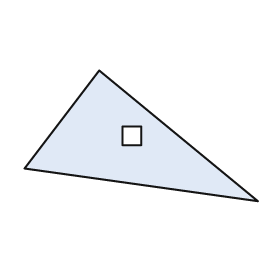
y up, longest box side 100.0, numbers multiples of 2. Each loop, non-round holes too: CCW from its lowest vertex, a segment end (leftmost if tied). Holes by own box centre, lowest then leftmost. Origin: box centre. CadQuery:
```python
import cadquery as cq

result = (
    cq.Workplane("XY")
    .moveTo(50.0, -28.0)
    .lineTo(-18.0, 28.0)
    .lineTo(-50.0, -14.0)
    .close()
    .moveTo(-8.0, -4.0)
    .lineTo(0.0, -4.0)
    .lineTo(0.0, 4.0)
    .lineTo(-8.0, 4.0)
    .close()
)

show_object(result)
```